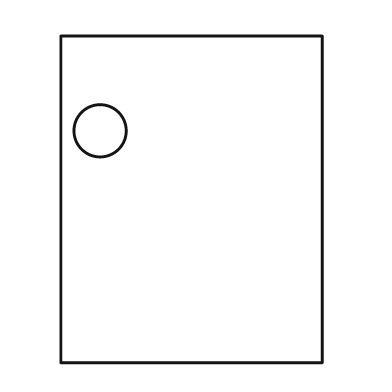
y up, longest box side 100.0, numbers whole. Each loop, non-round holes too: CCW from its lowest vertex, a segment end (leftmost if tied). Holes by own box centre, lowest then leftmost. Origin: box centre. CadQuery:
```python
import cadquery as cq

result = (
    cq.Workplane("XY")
    .moveTo(-40.0, -50.0)
    .lineTo(40.0, -50.0)
    .lineTo(40.0, 50.0)
    .lineTo(-40.0, 50.0)
    .close()
    .moveTo(-28.0, 21.0)
    .circle(8.0)
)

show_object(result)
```